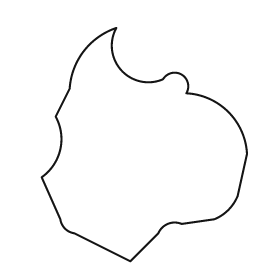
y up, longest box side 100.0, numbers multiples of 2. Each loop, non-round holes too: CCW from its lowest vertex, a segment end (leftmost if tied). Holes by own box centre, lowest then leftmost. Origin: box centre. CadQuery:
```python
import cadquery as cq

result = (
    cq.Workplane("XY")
    .moveTo(-6.0, -50.0)
    .lineTo(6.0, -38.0)
    .threePointArc((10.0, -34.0), (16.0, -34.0))
    .lineTo(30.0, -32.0)
    .threePointArc((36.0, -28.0), (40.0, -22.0))
    .lineTo(44.0, -4.0)
    .threePointArc((36.0, 14.0), (18.0, 22.0))
    .threePointArc((16.0, 30.0), (8.0, 28.0))
    .threePointArc((-10.0, 32.0), (-12.0, 50.0))
    .threePointArc((-26.0, 40.0), (-32.0, 24.0))
    .lineTo(-38.0, 12.0)
    .threePointArc((-36.0, -2.0), (-44.0, -14.0))
    .lineTo(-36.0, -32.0)
    .threePointArc((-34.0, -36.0), (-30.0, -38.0))
    .close()
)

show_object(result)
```